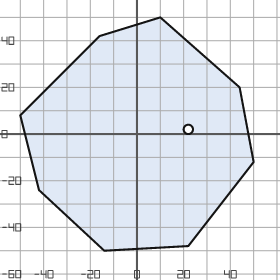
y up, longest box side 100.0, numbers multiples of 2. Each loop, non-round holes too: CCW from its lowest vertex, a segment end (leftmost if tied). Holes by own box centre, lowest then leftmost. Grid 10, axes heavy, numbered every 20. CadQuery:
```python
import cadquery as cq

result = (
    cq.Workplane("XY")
    .moveTo(-14.0, -50.0)
    .lineTo(22.0, -48.0)
    .lineTo(50.0, -12.0)
    .lineTo(44.0, 20.0)
    .lineTo(10.0, 50.0)
    .lineTo(-16.0, 42.0)
    .lineTo(-50.0, 8.0)
    .lineTo(-42.0, -24.0)
    .close()
    .moveTo(22.0, 2.0)
    .circle(2.0)
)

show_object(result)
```